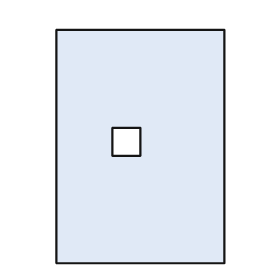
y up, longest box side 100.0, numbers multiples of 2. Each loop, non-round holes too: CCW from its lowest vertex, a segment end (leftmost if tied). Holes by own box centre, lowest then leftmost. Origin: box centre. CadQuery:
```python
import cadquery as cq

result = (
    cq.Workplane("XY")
    .moveTo(-36.0, -50.0)
    .lineTo(36.0, -50.0)
    .lineTo(36.0, 50.0)
    .lineTo(-36.0, 50.0)
    .close()
    .moveTo(-12.0, -4.0)
    .lineTo(0.0, -4.0)
    .lineTo(0.0, 8.0)
    .lineTo(-12.0, 8.0)
    .close()
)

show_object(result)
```